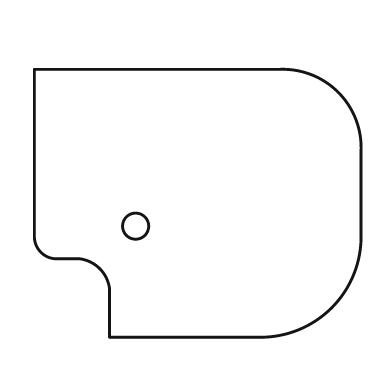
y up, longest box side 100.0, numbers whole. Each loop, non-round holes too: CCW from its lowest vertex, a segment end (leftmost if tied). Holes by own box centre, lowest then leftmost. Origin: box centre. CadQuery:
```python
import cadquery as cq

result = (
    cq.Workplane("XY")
    .moveTo(-27.0, -41.0)
    .lineTo(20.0, -41.0)
    .threePointArc((41.0, -32.0), (50.0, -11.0))
    .lineTo(50.0, 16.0)
    .threePointArc((43.0, 34.0), (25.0, 41.0))
    .lineTo(-50.0, 41.0)
    .lineTo(-50.0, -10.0)
    .threePointArc((-48.0, -15.0), (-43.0, -17.0))
    .lineTo(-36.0, -17.0)
    .threePointArc((-30.0, -20.0), (-27.0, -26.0))
    .close()
    .moveTo(-19.0, -7.0)
    .circle(4.0)
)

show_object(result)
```